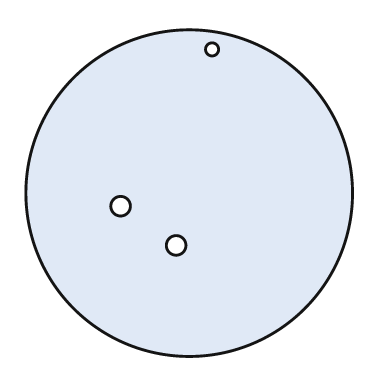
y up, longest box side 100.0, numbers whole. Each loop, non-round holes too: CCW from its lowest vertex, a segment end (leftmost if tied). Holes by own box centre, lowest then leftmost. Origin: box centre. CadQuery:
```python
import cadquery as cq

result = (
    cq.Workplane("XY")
    .moveTo(0.0, 0.0)
    .circle(50.0)
    .moveTo(-4.0, -16.0)
    .circle(3.0)
    .moveTo(-21.0, -4.0)
    .circle(3.0)
    .moveTo(7.0, 44.0)
    .circle(2.0)
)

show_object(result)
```